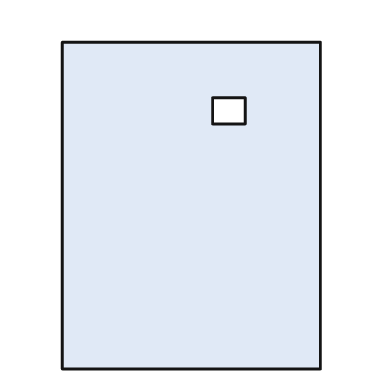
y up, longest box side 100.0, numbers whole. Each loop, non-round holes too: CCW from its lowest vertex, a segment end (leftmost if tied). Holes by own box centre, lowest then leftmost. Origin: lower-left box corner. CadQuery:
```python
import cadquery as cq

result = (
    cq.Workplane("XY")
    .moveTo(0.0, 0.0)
    .lineTo(79.0, 0.0)
    .lineTo(79.0, 100.0)
    .lineTo(0.0, 100.0)
    .close()
    .moveTo(46.0, 75.0)
    .lineTo(56.0, 75.0)
    .lineTo(56.0, 83.0)
    .lineTo(46.0, 83.0)
    .close()
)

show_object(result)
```